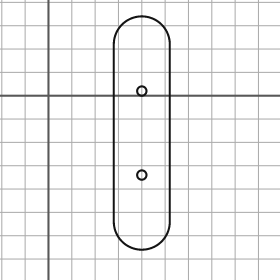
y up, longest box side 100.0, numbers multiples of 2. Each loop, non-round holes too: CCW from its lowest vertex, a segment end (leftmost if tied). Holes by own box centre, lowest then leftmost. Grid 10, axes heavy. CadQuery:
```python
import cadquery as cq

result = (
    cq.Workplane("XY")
    .moveTo(28.0, -54.0)
    .threePointArc((40.0, -66.0), (52.0, -54.0))
    .lineTo(52.0, 22.0)
    .threePointArc((40.0, 34.0), (28.0, 22.0))
    .close()
    .moveTo(40.0, -34.0)
    .circle(2.0)
    .moveTo(40.0, 2.0)
    .circle(2.0)
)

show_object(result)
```